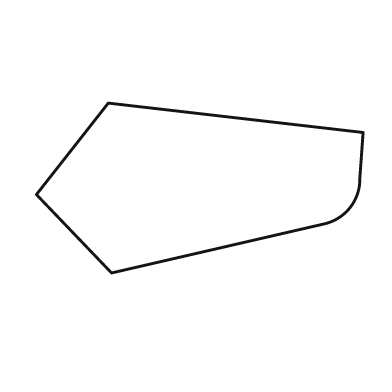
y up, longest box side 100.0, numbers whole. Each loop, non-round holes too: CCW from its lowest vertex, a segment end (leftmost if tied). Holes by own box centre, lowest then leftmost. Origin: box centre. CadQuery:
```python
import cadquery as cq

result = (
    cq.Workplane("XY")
    .moveTo(-27.0, -26.0)
    .lineTo(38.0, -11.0)
    .threePointArc((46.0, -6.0), (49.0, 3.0))
    .lineTo(50.0, 17.0)
    .lineTo(-28.0, 26.0)
    .lineTo(-50.0, -2.0)
    .close()
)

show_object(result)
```